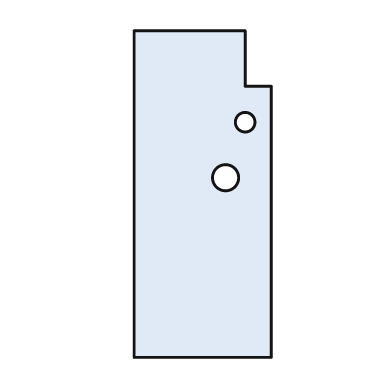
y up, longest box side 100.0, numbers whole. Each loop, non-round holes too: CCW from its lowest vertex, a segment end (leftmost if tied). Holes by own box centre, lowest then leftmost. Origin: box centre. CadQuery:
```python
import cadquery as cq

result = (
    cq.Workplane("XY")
    .moveTo(-21.0, -50.0)
    .lineTo(21.0, -50.0)
    .lineTo(21.0, 33.0)
    .lineTo(13.0, 33.0)
    .lineTo(13.0, 50.0)
    .lineTo(-21.0, 50.0)
    .close()
    .moveTo(7.0, 5.0)
    .circle(4.0)
    .moveTo(13.0, 22.0)
    .circle(3.0)
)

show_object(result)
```